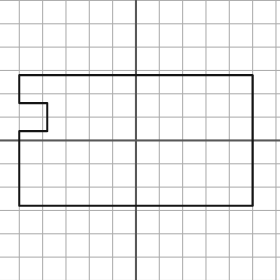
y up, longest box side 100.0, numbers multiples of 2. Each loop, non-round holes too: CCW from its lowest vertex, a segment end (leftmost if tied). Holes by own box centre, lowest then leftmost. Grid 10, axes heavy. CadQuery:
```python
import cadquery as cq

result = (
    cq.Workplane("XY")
    .moveTo(-50.0, -28.0)
    .lineTo(50.0, -28.0)
    .lineTo(50.0, 28.0)
    .lineTo(-50.0, 28.0)
    .lineTo(-50.0, 16.0)
    .lineTo(-38.0, 16.0)
    .lineTo(-38.0, 4.0)
    .lineTo(-50.0, 4.0)
    .close()
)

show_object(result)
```